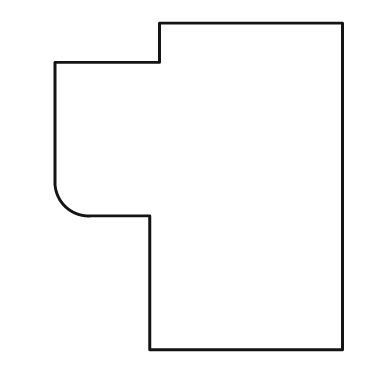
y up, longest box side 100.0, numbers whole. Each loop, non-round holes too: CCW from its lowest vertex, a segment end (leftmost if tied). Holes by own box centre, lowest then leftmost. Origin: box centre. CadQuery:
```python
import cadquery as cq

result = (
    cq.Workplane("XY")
    .moveTo(-15.0, -50.0)
    .lineTo(44.0, -50.0)
    .lineTo(44.0, 50.0)
    .lineTo(-12.0, 50.0)
    .lineTo(-12.0, 38.0)
    .lineTo(-44.0, 38.0)
    .lineTo(-44.0, 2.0)
    .threePointArc((-41.0, -6.0), (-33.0, -9.0))
    .lineTo(-15.0, -9.0)
    .close()
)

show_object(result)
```